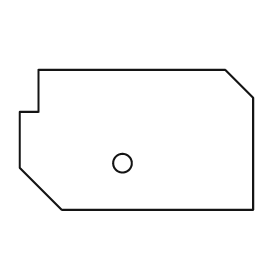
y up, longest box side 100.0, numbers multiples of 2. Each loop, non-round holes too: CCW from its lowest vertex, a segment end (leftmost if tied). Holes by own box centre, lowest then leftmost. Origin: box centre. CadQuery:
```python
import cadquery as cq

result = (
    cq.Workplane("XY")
    .moveTo(-32.0, -30.0)
    .lineTo(50.0, -30.0)
    .lineTo(50.0, 18.0)
    .lineTo(38.0, 30.0)
    .lineTo(-42.0, 30.0)
    .lineTo(-42.0, 12.0)
    .lineTo(-50.0, 12.0)
    .lineTo(-50.0, -12.0)
    .close()
    .moveTo(-6.0, -10.0)
    .circle(4.0)
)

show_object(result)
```